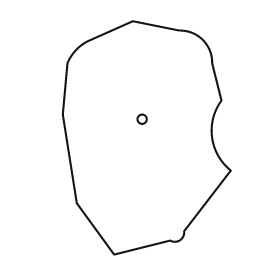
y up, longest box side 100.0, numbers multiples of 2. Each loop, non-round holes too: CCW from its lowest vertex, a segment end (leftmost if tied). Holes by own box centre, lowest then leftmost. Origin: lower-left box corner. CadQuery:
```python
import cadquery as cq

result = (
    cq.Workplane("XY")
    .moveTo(22.0, 0.0)
    .lineTo(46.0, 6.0)
    .threePointArc((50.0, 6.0), (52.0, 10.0))
    .lineTo(72.0, 36.0)
    .threePointArc((64.0, 50.0), (68.0, 66.0))
    .lineTo(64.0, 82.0)
    .threePointArc((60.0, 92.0), (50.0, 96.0))
    .lineTo(30.0, 100.0)
    .lineTo(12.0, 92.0)
    .threePointArc((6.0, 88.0), (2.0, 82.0))
    .lineTo(0.0, 60.0)
    .lineTo(6.0, 22.0)
    .close()
    .moveTo(34.0, 58.0)
    .circle(2.0)
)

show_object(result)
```